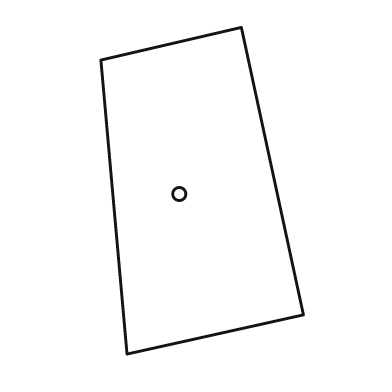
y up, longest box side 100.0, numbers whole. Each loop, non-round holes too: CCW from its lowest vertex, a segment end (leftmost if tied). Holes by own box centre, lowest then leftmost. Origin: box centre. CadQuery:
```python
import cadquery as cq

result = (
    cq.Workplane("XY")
    .moveTo(-23.0, -50.0)
    .lineTo(31.0, -38.0)
    .lineTo(12.0, 50.0)
    .lineTo(-31.0, 40.0)
    .close()
    .moveTo(-7.0, -1.0)
    .circle(2.0)
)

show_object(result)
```